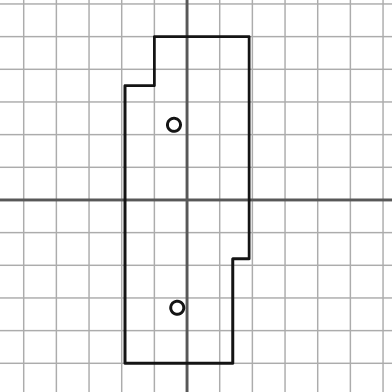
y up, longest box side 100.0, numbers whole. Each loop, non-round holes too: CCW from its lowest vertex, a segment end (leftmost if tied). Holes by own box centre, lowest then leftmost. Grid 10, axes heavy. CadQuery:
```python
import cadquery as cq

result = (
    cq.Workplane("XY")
    .moveTo(-19.0, -50.0)
    .lineTo(14.0, -50.0)
    .lineTo(14.0, -18.0)
    .lineTo(19.0, -18.0)
    .lineTo(19.0, 50.0)
    .lineTo(-10.0, 50.0)
    .lineTo(-10.0, 35.0)
    .lineTo(-19.0, 35.0)
    .close()
    .moveTo(-3.0, -33.0)
    .circle(2.0)
    .moveTo(-4.0, 23.0)
    .circle(2.0)
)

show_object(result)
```